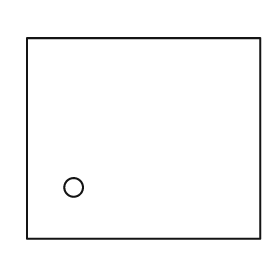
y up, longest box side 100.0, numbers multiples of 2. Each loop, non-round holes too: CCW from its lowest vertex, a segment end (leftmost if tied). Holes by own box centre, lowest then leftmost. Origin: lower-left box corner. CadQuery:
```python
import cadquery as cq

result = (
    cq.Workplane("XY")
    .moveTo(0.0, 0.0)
    .lineTo(100.0, 0.0)
    .lineTo(100.0, 86.0)
    .lineTo(0.0, 86.0)
    .close()
    .moveTo(20.0, 22.0)
    .circle(4.0)
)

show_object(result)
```